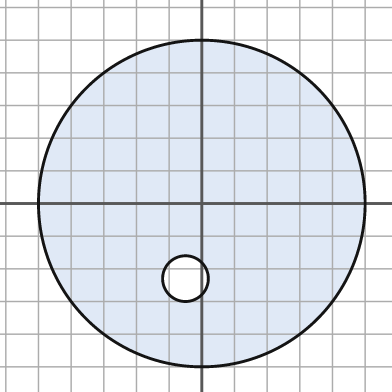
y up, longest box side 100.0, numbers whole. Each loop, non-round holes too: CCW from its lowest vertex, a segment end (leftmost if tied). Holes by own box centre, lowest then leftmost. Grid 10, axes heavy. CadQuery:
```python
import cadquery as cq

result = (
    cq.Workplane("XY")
    .moveTo(0.0, 0.0)
    .circle(50.0)
    .moveTo(-5.0, -23.0)
    .circle(7.0)
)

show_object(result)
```